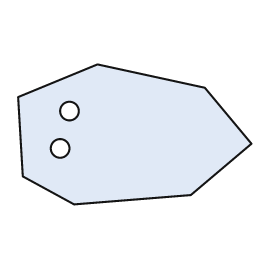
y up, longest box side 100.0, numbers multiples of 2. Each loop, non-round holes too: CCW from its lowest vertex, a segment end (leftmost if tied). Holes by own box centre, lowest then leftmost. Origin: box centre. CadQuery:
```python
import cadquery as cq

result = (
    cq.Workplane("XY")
    .moveTo(-26.0, -30.0)
    .lineTo(24.0, -26.0)
    .lineTo(50.0, -4.0)
    .lineTo(30.0, 20.0)
    .lineTo(-16.0, 30.0)
    .lineTo(-50.0, 16.0)
    .lineTo(-48.0, -18.0)
    .close()
    .moveTo(-32.0, -6.0)
    .circle(4.0)
    .moveTo(-28.0, 10.0)
    .circle(4.0)
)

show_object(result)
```